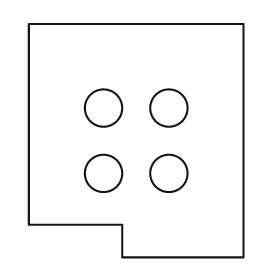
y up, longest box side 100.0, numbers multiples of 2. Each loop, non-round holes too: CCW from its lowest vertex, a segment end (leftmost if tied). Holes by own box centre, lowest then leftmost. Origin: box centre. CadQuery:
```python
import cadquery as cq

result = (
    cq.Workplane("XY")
    .moveTo(-6.0, -50.0)
    .lineTo(46.0, -50.0)
    .lineTo(46.0, 50.0)
    .lineTo(-46.0, 50.0)
    .lineTo(-46.0, -36.0)
    .lineTo(-6.0, -36.0)
    .close()
    .moveTo(-14.0, -14.0)
    .circle(8.0)
    .moveTo(14.0, -14.0)
    .circle(8.0)
    .moveTo(-14.0, 14.0)
    .circle(8.0)
    .moveTo(14.0, 14.0)
    .circle(8.0)
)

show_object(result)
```